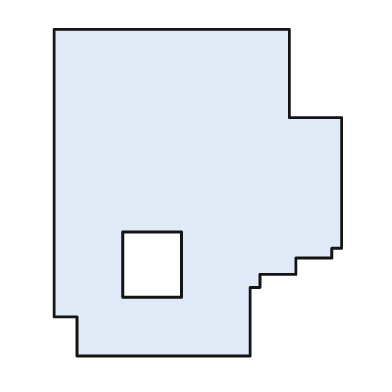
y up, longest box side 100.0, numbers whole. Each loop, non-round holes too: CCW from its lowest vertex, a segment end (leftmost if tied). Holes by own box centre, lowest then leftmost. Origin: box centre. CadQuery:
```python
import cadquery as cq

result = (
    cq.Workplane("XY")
    .moveTo(-37.0, -50.0)
    .lineTo(16.0, -50.0)
    .lineTo(16.0, -29.0)
    .lineTo(19.0, -29.0)
    .lineTo(19.0, -25.0)
    .lineTo(30.0, -25.0)
    .lineTo(30.0, -20.0)
    .lineTo(41.0, -20.0)
    .lineTo(41.0, -17.0)
    .lineTo(44.0, -17.0)
    .lineTo(44.0, 23.0)
    .lineTo(28.0, 23.0)
    .lineTo(28.0, 50.0)
    .lineTo(-44.0, 50.0)
    .lineTo(-44.0, -38.0)
    .lineTo(-37.0, -38.0)
    .close()
    .moveTo(-23.0, -32.0)
    .lineTo(-5.0, -32.0)
    .lineTo(-5.0, -12.0)
    .lineTo(-23.0, -12.0)
    .close()
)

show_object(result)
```